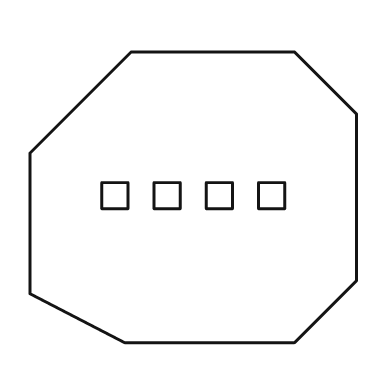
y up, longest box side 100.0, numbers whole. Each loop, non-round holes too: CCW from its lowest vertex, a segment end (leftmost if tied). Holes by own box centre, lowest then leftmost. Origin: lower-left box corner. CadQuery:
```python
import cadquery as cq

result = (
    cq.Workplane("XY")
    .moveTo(29.0, 0.0)
    .lineTo(81.0, 0.0)
    .lineTo(100.0, 19.0)
    .lineTo(100.0, 70.0)
    .lineTo(81.0, 89.0)
    .lineTo(31.0, 89.0)
    .lineTo(0.0, 58.0)
    .lineTo(0.0, 15.0)
    .close()
    .moveTo(22.0, 41.0)
    .lineTo(30.0, 41.0)
    .lineTo(30.0, 49.0)
    .lineTo(22.0, 49.0)
    .close()
    .moveTo(38.0, 41.0)
    .lineTo(46.0, 41.0)
    .lineTo(46.0, 49.0)
    .lineTo(38.0, 49.0)
    .close()
    .moveTo(54.0, 41.0)
    .lineTo(62.0, 41.0)
    .lineTo(62.0, 49.0)
    .lineTo(54.0, 49.0)
    .close()
    .moveTo(70.0, 41.0)
    .lineTo(78.0, 41.0)
    .lineTo(78.0, 49.0)
    .lineTo(70.0, 49.0)
    .close()
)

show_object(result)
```